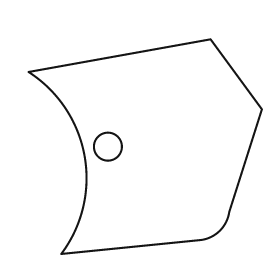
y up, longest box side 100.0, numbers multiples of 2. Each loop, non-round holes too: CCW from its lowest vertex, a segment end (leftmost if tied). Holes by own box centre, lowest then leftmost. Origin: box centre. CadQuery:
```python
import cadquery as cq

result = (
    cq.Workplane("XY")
    .moveTo(-36.0, -46.0)
    .lineTo(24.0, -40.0)
    .threePointArc((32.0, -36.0), (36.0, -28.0))
    .lineTo(50.0, 16.0)
    .lineTo(28.0, 46.0)
    .lineTo(-50.0, 32.0)
    .threePointArc((-26.0, -4.0), (-36.0, -46.0))
    .close()
    .moveTo(-16.0, 0.0)
    .circle(6.0)
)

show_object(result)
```